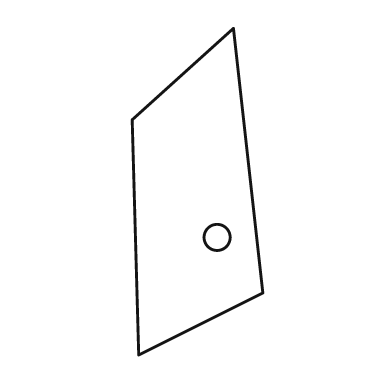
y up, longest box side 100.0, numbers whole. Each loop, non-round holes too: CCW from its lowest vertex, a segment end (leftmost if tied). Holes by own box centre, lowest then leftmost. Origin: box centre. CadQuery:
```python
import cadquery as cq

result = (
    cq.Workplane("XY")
    .moveTo(-18.0, -50.0)
    .lineTo(20.0, -31.0)
    .lineTo(11.0, 50.0)
    .lineTo(-20.0, 22.0)
    .close()
    .moveTo(6.0, -14.0)
    .circle(4.0)
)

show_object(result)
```